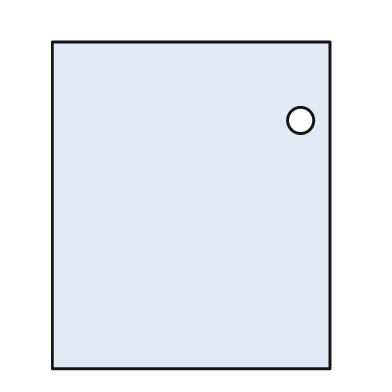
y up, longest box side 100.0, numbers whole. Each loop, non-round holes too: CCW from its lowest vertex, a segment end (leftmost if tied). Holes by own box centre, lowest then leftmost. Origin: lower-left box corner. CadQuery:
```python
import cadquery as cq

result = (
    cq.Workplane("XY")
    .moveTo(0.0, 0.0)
    .lineTo(85.0, 0.0)
    .lineTo(85.0, 100.0)
    .lineTo(0.0, 100.0)
    .close()
    .moveTo(76.0, 76.0)
    .circle(4.0)
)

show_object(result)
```